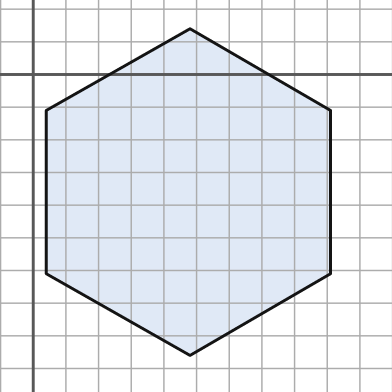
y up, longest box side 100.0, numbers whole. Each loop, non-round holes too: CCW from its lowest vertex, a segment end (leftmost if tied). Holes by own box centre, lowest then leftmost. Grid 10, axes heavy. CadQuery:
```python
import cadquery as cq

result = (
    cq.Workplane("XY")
    .moveTo(48.0, -86.0)
    .lineTo(91.0, -61.0)
    .lineTo(91.0, -11.0)
    .lineTo(48.0, 14.0)
    .lineTo(4.0, -11.0)
    .lineTo(4.0, -61.0)
    .close()
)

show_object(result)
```